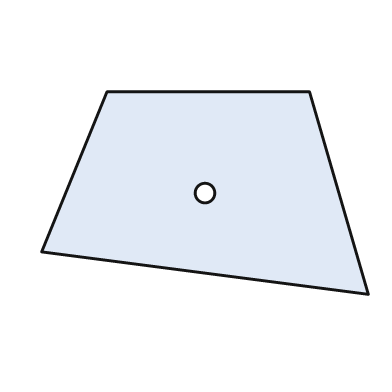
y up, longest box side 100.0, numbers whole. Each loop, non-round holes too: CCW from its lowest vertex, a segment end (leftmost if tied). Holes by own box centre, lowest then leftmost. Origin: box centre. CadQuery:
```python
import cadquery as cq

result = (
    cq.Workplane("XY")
    .moveTo(50.0, -31.0)
    .lineTo(32.0, 31.0)
    .lineTo(-30.0, 31.0)
    .lineTo(-50.0, -18.0)
    .close()
    .moveTo(0.0, 0.0)
    .circle(3.0)
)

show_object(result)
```